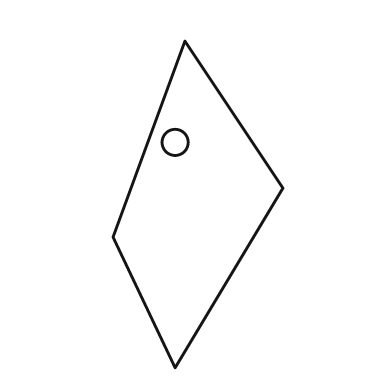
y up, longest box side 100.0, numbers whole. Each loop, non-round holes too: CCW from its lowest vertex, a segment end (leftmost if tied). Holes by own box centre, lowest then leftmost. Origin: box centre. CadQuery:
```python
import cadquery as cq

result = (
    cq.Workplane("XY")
    .moveTo(-7.0, -50.0)
    .lineTo(26.0, 5.0)
    .lineTo(-4.0, 50.0)
    .lineTo(-26.0, -10.0)
    .close()
    .moveTo(-7.0, 19.0)
    .circle(4.0)
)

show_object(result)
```